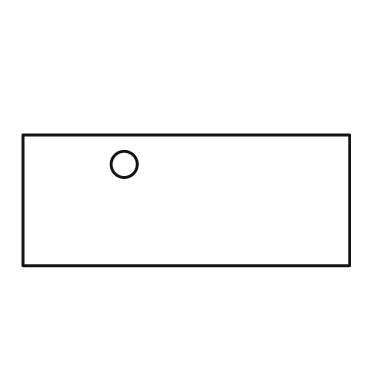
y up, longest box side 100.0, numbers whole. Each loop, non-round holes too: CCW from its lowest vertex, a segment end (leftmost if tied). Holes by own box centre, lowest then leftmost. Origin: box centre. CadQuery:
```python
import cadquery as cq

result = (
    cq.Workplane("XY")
    .moveTo(-50.0, -20.0)
    .lineTo(50.0, -20.0)
    .lineTo(50.0, 20.0)
    .lineTo(-50.0, 20.0)
    .close()
    .moveTo(-19.0, 11.0)
    .circle(4.0)
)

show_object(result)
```